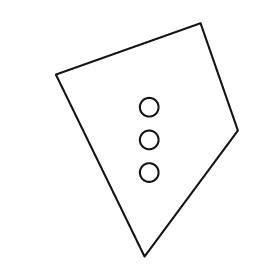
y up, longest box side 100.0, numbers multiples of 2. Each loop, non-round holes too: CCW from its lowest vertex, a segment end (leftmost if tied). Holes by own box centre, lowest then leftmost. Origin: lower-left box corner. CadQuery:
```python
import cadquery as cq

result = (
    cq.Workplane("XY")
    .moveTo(38.0, 0.0)
    .lineTo(78.0, 54.0)
    .lineTo(62.0, 100.0)
    .lineTo(0.0, 78.0)
    .close()
    .moveTo(40.0, 36.0)
    .circle(4.0)
    .moveTo(40.0, 50.0)
    .circle(4.0)
    .moveTo(40.0, 64.0)
    .circle(4.0)
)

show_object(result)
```